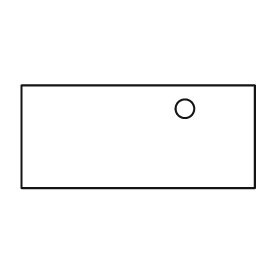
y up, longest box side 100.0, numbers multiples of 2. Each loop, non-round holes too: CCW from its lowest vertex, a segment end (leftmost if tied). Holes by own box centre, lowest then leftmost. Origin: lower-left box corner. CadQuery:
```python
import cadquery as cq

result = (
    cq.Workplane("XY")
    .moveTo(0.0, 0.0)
    .lineTo(100.0, 0.0)
    .lineTo(100.0, 44.0)
    .lineTo(0.0, 44.0)
    .close()
    .moveTo(70.0, 34.0)
    .circle(4.0)
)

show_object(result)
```